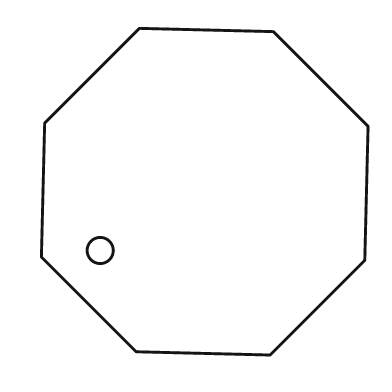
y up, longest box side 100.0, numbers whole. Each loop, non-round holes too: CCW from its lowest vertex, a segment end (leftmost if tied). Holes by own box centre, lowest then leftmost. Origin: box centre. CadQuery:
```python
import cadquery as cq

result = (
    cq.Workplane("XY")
    .moveTo(20.0, -50.0)
    .lineTo(49.0, -21.0)
    .lineTo(50.0, 20.0)
    .lineTo(21.0, 49.0)
    .lineTo(-20.0, 50.0)
    .lineTo(-49.0, 21.0)
    .lineTo(-50.0, -20.0)
    .lineTo(-21.0, -49.0)
    .close()
    .moveTo(-32.0, -18.0)
    .circle(4.0)
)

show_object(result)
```